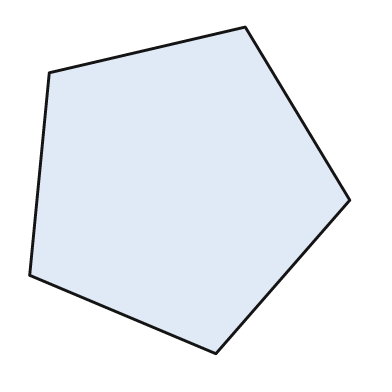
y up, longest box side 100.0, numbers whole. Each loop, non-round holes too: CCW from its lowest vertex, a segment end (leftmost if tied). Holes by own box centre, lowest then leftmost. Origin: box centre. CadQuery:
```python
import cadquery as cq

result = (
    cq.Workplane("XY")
    .moveTo(8.0, -50.0)
    .lineTo(49.0, -3.0)
    .lineTo(17.0, 50.0)
    .lineTo(-43.0, 36.0)
    .lineTo(-49.0, -26.0)
    .close()
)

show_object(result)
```